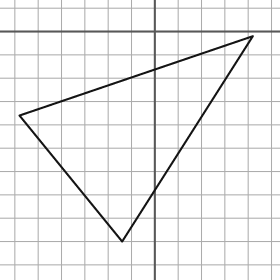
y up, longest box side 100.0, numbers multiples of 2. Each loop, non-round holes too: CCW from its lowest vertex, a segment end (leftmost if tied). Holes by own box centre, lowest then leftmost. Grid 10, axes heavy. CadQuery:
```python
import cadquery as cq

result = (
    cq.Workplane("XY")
    .moveTo(-14.0, -90.0)
    .lineTo(42.0, -2.0)
    .lineTo(-58.0, -36.0)
    .close()
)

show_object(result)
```